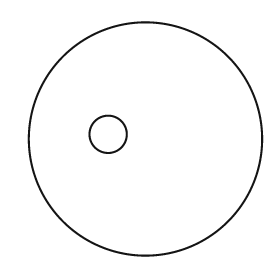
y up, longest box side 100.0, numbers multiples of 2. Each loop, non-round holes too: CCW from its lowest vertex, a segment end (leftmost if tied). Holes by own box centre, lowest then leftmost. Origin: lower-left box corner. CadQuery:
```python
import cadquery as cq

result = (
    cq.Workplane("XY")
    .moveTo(50.0, 50.0)
    .circle(50.0)
    .moveTo(34.0, 52.0)
    .circle(8.0)
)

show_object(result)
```